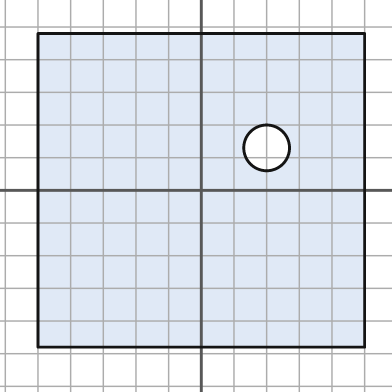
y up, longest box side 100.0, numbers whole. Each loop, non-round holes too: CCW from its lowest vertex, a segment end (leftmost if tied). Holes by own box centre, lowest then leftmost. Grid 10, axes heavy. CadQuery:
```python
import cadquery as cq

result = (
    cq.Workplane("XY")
    .moveTo(-50.0, -48.0)
    .lineTo(50.0, -48.0)
    .lineTo(50.0, 48.0)
    .lineTo(-50.0, 48.0)
    .close()
    .moveTo(20.0, 13.0)
    .circle(7.0)
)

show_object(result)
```